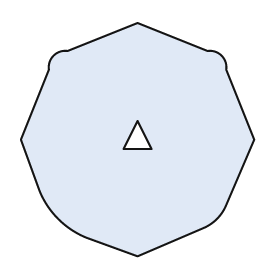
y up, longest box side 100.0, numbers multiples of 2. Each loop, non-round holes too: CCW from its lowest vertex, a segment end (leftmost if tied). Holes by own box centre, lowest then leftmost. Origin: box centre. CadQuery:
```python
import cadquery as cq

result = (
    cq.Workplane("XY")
    .moveTo(0.0, -50.0)
    .lineTo(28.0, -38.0)
    .threePointArc((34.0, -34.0), (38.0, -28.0))
    .lineTo(50.0, 0.0)
    .lineTo(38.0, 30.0)
    .threePointArc((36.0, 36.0), (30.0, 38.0))
    .lineTo(0.0, 50.0)
    .lineTo(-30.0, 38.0)
    .threePointArc((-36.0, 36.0), (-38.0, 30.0))
    .lineTo(-50.0, 0.0)
    .lineTo(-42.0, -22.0)
    .threePointArc((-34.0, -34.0), (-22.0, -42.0))
    .close()
    .moveTo(-6.0, -4.0)
    .lineTo(6.0, -4.0)
    .lineTo(0.0, 8.0)
    .close()
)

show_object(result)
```